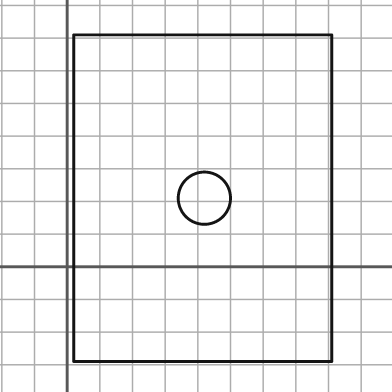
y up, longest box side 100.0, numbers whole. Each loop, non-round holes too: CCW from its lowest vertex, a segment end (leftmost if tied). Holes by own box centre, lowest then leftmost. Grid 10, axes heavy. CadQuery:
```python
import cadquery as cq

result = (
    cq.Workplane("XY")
    .moveTo(2.0, -29.0)
    .lineTo(81.0, -29.0)
    .lineTo(81.0, 71.0)
    .lineTo(2.0, 71.0)
    .close()
    .moveTo(42.0, 21.0)
    .circle(8.0)
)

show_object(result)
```